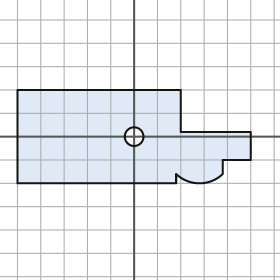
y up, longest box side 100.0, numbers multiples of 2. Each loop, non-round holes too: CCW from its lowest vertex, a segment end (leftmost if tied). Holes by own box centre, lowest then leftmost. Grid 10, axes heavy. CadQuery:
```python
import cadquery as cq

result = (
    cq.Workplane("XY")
    .moveTo(-50.0, -20.0)
    .lineTo(18.0, -20.0)
    .lineTo(18.0, -16.0)
    .threePointArc((28.0, -20.0), (38.0, -16.0))
    .lineTo(38.0, -10.0)
    .lineTo(50.0, -10.0)
    .lineTo(50.0, 2.0)
    .lineTo(20.0, 2.0)
    .lineTo(20.0, 20.0)
    .lineTo(-50.0, 20.0)
    .close()
    .moveTo(0.0, 0.0)
    .circle(4.0)
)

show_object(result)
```